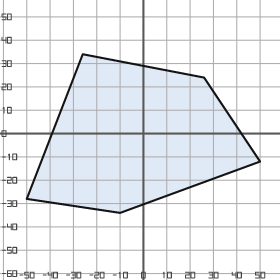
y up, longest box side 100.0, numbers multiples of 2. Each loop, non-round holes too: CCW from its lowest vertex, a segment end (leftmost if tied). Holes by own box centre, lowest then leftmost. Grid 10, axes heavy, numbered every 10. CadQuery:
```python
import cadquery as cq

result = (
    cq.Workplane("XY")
    .moveTo(-10.0, -34.0)
    .lineTo(50.0, -12.0)
    .lineTo(26.0, 24.0)
    .lineTo(-26.0, 34.0)
    .lineTo(-50.0, -28.0)
    .close()
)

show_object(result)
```